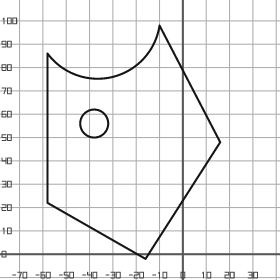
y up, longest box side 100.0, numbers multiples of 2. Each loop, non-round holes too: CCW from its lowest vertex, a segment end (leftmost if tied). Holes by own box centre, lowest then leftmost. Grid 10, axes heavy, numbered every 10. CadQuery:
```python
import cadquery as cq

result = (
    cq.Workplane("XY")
    .moveTo(-16.0, -2.0)
    .lineTo(16.0, 48.0)
    .lineTo(-10.0, 98.0)
    .threePointArc((-30.0, 76.0), (-58.0, 86.0))
    .lineTo(-58.0, 22.0)
    .close()
    .moveTo(-38.0, 56.0)
    .circle(6.0)
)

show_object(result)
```